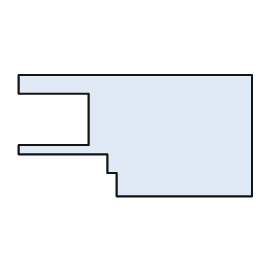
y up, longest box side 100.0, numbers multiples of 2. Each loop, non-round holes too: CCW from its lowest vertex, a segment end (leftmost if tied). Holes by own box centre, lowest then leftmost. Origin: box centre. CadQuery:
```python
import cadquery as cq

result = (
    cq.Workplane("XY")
    .moveTo(-8.0, -26.0)
    .lineTo(50.0, -26.0)
    .lineTo(50.0, 26.0)
    .lineTo(-50.0, 26.0)
    .lineTo(-50.0, 18.0)
    .lineTo(-20.0, 18.0)
    .lineTo(-20.0, -4.0)
    .lineTo(-50.0, -4.0)
    .lineTo(-50.0, -8.0)
    .lineTo(-12.0, -8.0)
    .lineTo(-12.0, -16.0)
    .lineTo(-8.0, -16.0)
    .close()
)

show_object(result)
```